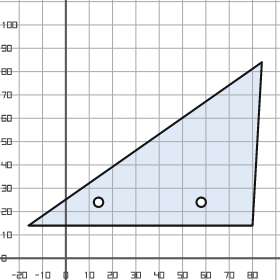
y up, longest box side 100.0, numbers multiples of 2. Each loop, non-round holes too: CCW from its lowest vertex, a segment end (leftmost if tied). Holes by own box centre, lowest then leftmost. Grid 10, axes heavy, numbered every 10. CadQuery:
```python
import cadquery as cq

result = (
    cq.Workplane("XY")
    .moveTo(-16.0, 14.0)
    .lineTo(80.0, 14.0)
    .lineTo(84.0, 84.0)
    .close()
    .moveTo(14.0, 24.0)
    .circle(2.0)
    .moveTo(58.0, 24.0)
    .circle(2.0)
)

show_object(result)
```